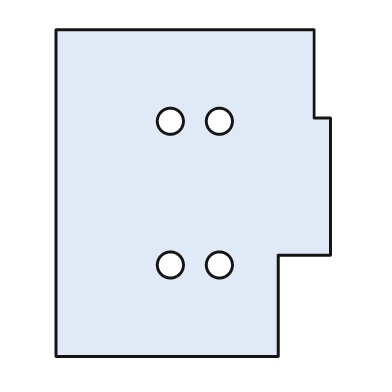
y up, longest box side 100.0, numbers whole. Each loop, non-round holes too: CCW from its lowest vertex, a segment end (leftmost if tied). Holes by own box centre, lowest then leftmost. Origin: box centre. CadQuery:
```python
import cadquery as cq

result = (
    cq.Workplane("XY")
    .moveTo(-42.0, -50.0)
    .lineTo(26.0, -50.0)
    .lineTo(26.0, -19.0)
    .lineTo(42.0, -19.0)
    .lineTo(42.0, 23.0)
    .lineTo(37.0, 23.0)
    .lineTo(37.0, 50.0)
    .lineTo(-42.0, 50.0)
    .close()
    .moveTo(-7.0, -22.0)
    .circle(4.0)
    .moveTo(8.0, -22.0)
    .circle(4.0)
    .moveTo(-7.0, 22.0)
    .circle(4.0)
    .moveTo(8.0, 22.0)
    .circle(4.0)
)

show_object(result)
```